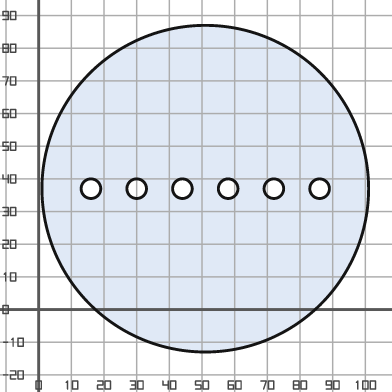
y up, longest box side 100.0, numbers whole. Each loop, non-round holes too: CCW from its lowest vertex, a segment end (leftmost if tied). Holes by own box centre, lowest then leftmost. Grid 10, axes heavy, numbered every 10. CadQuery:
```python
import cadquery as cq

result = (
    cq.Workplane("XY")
    .moveTo(51.0, 37.0)
    .circle(50.0)
    .moveTo(16.0, 37.0)
    .circle(3.0)
    .moveTo(30.0, 37.0)
    .circle(3.0)
    .moveTo(44.0, 37.0)
    .circle(3.0)
    .moveTo(58.0, 37.0)
    .circle(3.0)
    .moveTo(72.0, 37.0)
    .circle(3.0)
    .moveTo(86.0, 37.0)
    .circle(3.0)
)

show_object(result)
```